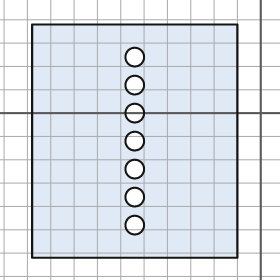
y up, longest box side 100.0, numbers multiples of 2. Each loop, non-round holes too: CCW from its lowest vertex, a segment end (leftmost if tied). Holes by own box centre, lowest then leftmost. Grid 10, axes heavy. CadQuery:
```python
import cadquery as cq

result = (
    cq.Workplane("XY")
    .moveTo(-98.0, -62.0)
    .lineTo(-10.0, -62.0)
    .lineTo(-10.0, 38.0)
    .lineTo(-98.0, 38.0)
    .close()
    .moveTo(-54.0, -48.0)
    .circle(4.0)
    .moveTo(-54.0, -36.0)
    .circle(4.0)
    .moveTo(-54.0, -24.0)
    .circle(4.0)
    .moveTo(-54.0, -12.0)
    .circle(4.0)
    .moveTo(-54.0, 0.0)
    .circle(4.0)
    .moveTo(-54.0, 12.0)
    .circle(4.0)
    .moveTo(-54.0, 24.0)
    .circle(4.0)
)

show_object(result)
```